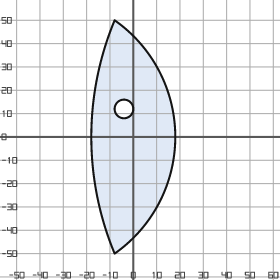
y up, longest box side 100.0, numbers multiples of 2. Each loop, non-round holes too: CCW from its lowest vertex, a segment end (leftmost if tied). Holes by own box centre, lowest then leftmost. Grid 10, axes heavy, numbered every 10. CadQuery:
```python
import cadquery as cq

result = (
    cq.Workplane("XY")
    .moveTo(-8.0, -50.0)
    .threePointArc((18.0, 0.0), (-8.0, 50.0))
    .threePointArc((-18.0, 0.0), (-8.0, -50.0))
    .close()
    .moveTo(-4.0, 12.0)
    .circle(4.0)
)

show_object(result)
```